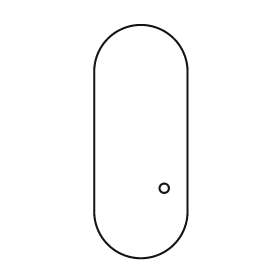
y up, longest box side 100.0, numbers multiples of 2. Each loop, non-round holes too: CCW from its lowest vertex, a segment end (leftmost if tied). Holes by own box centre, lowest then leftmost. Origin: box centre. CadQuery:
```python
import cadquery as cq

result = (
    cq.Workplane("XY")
    .moveTo(-20.0, -30.0)
    .threePointArc((0.0, -50.0), (20.0, -30.0))
    .lineTo(20.0, 30.0)
    .threePointArc((0.0, 50.0), (-20.0, 30.0))
    .close()
    .moveTo(10.0, -20.0)
    .circle(2.0)
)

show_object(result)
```